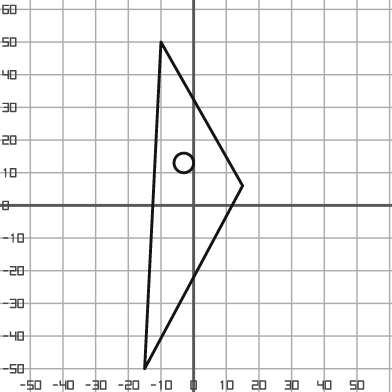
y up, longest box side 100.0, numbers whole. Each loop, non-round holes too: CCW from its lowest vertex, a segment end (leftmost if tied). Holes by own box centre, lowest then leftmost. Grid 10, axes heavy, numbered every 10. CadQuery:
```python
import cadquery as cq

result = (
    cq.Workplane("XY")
    .moveTo(-15.0, -50.0)
    .lineTo(15.0, 6.0)
    .lineTo(-10.0, 50.0)
    .close()
    .moveTo(-3.0, 13.0)
    .circle(3.0)
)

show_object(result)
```